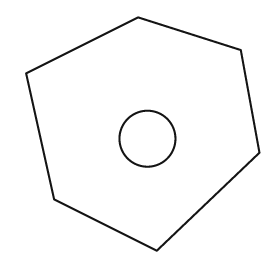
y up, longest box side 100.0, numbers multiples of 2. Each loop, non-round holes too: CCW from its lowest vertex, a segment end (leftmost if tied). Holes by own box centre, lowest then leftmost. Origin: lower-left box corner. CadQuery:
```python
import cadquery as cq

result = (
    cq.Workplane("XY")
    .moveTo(56.0, 0.0)
    .lineTo(100.0, 42.0)
    .lineTo(92.0, 86.0)
    .lineTo(48.0, 100.0)
    .lineTo(0.0, 76.0)
    .lineTo(12.0, 22.0)
    .close()
    .moveTo(52.0, 48.0)
    .circle(12.0)
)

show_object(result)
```